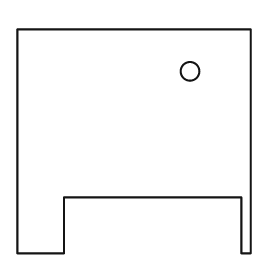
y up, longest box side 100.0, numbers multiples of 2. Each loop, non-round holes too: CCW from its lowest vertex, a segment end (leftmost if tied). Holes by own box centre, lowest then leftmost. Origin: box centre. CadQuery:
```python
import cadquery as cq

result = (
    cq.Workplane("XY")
    .moveTo(-50.0, -48.0)
    .lineTo(-30.0, -48.0)
    .lineTo(-30.0, -24.0)
    .lineTo(46.0, -24.0)
    .lineTo(46.0, -48.0)
    .lineTo(50.0, -48.0)
    .lineTo(50.0, 48.0)
    .lineTo(-50.0, 48.0)
    .close()
    .moveTo(24.0, 30.0)
    .circle(4.0)
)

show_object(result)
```